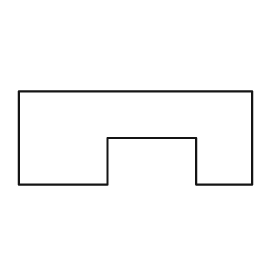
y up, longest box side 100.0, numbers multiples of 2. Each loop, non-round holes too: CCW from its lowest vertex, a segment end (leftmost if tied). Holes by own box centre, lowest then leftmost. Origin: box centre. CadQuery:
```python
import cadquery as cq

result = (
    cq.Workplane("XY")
    .moveTo(-50.0, -20.0)
    .lineTo(-12.0, -20.0)
    .lineTo(-12.0, 0.0)
    .lineTo(26.0, 0.0)
    .lineTo(26.0, -20.0)
    .lineTo(50.0, -20.0)
    .lineTo(50.0, 20.0)
    .lineTo(-50.0, 20.0)
    .close()
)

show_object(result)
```